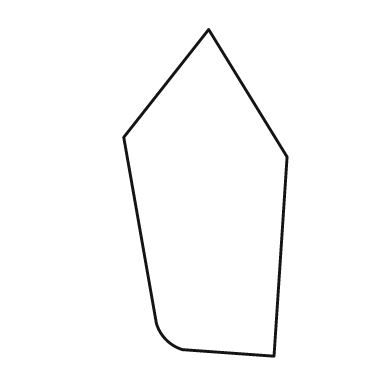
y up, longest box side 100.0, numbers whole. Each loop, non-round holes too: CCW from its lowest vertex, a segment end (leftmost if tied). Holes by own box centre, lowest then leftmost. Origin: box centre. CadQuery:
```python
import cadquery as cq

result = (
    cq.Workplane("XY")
    .moveTo(21.0, -50.0)
    .lineTo(25.0, 11.0)
    .lineTo(1.0, 50.0)
    .lineTo(-25.0, 17.0)
    .lineTo(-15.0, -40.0)
    .threePointArc((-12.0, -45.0), (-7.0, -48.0))
    .close()
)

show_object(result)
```